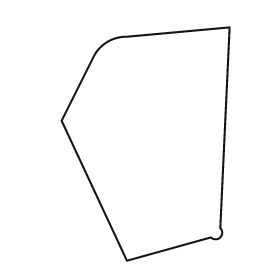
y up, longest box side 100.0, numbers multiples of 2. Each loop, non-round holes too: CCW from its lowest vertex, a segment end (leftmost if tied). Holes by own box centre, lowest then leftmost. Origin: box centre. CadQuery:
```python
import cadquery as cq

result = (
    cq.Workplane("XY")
    .moveTo(-8.0, -50.0)
    .lineTo(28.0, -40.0)
    .threePointArc((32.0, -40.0), (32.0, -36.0))
    .lineTo(36.0, 50.0)
    .lineTo(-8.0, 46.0)
    .threePointArc((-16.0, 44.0), (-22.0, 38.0))
    .lineTo(-36.0, 10.0)
    .close()
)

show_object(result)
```